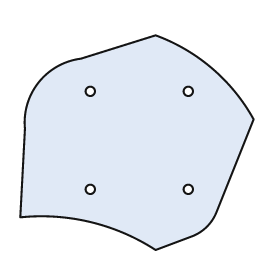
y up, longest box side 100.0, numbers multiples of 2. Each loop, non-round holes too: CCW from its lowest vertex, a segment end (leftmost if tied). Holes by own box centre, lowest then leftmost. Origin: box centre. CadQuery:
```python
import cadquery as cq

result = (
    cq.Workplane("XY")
    .moveTo(8.0, -46.0)
    .lineTo(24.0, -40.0)
    .threePointArc((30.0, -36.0), (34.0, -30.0))
    .lineTo(50.0, 10.0)
    .threePointArc((32.0, 32.0), (8.0, 46.0))
    .lineTo(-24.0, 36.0)
    .threePointArc((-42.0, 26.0), (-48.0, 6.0))
    .lineTo(-50.0, -32.0)
    .threePointArc((-20.0, -34.0), (8.0, -46.0))
    .close()
    .moveTo(-20.0, -20.0)
    .circle(2.0)
    .moveTo(22.0, -20.0)
    .circle(2.0)
    .moveTo(-20.0, 22.0)
    .circle(2.0)
    .moveTo(22.0, 22.0)
    .circle(2.0)
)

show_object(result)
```